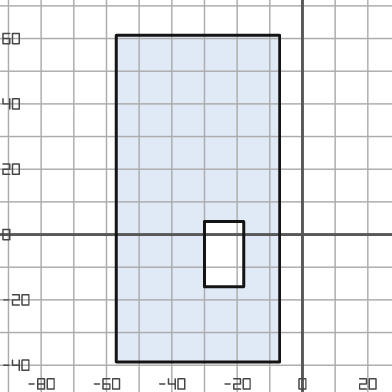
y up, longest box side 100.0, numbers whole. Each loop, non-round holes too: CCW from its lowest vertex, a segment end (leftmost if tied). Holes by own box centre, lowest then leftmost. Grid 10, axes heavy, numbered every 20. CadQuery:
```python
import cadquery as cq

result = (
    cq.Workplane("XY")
    .moveTo(-57.0, -39.0)
    .lineTo(-7.0, -39.0)
    .lineTo(-7.0, 61.0)
    .lineTo(-57.0, 61.0)
    .close()
    .moveTo(-30.0, -16.0)
    .lineTo(-18.0, -16.0)
    .lineTo(-18.0, 4.0)
    .lineTo(-30.0, 4.0)
    .close()
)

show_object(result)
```